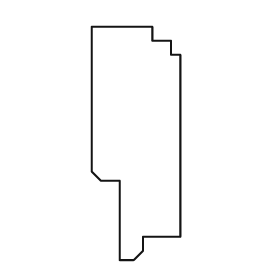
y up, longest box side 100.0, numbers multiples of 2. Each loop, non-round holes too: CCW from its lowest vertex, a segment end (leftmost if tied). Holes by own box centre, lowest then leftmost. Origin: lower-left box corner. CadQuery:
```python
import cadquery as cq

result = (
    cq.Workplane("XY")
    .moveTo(12.0, 0.0)
    .lineTo(18.0, 0.0)
    .lineTo(22.0, 4.0)
    .lineTo(22.0, 10.0)
    .lineTo(38.0, 10.0)
    .lineTo(38.0, 88.0)
    .lineTo(34.0, 88.0)
    .lineTo(34.0, 94.0)
    .lineTo(26.0, 94.0)
    .lineTo(26.0, 100.0)
    .lineTo(0.0, 100.0)
    .lineTo(0.0, 38.0)
    .lineTo(4.0, 34.0)
    .lineTo(12.0, 34.0)
    .close()
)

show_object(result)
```